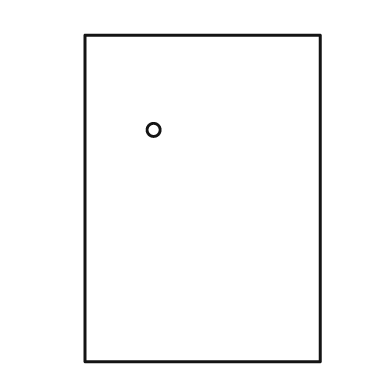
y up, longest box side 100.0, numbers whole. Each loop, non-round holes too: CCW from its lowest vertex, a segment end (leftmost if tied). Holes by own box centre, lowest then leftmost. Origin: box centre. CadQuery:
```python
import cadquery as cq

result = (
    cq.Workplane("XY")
    .moveTo(-36.0, -50.0)
    .lineTo(36.0, -50.0)
    .lineTo(36.0, 50.0)
    .lineTo(-36.0, 50.0)
    .close()
    .moveTo(-15.0, 21.0)
    .circle(2.0)
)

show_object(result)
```